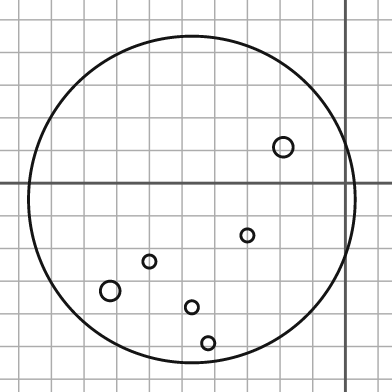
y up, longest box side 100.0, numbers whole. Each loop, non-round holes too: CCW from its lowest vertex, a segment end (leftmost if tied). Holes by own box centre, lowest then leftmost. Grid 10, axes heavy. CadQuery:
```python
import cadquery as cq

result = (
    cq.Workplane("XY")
    .moveTo(-47.0, -5.0)
    .circle(50.0)
    .moveTo(-42.0, -49.0)
    .circle(2.0)
    .moveTo(-47.0, -38.0)
    .circle(2.0)
    .moveTo(-72.0, -33.0)
    .circle(3.0)
    .moveTo(-60.0, -24.0)
    .circle(2.0)
    .moveTo(-30.0, -16.0)
    .circle(2.0)
    .moveTo(-19.0, 11.0)
    .circle(3.0)
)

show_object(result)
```